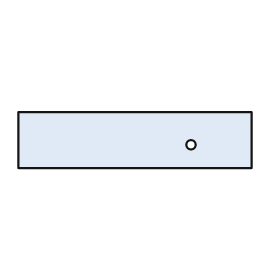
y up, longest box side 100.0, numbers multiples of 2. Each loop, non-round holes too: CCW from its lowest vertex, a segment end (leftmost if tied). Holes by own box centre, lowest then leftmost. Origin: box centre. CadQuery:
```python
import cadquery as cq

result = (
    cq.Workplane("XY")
    .moveTo(-50.0, -12.0)
    .lineTo(50.0, -12.0)
    .lineTo(50.0, 12.0)
    .lineTo(-50.0, 12.0)
    .close()
    .moveTo(24.0, -2.0)
    .circle(2.0)
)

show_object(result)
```